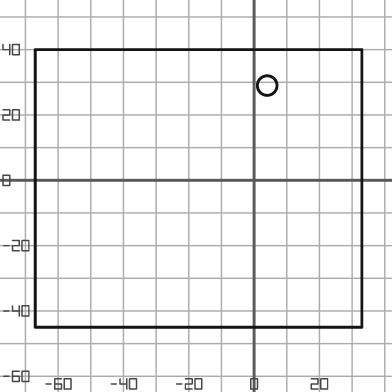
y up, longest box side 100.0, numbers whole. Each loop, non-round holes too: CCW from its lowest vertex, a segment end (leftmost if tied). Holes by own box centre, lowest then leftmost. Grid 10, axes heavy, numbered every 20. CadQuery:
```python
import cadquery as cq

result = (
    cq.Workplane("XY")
    .moveTo(-67.0, -45.0)
    .lineTo(33.0, -45.0)
    .lineTo(33.0, 40.0)
    .lineTo(-67.0, 40.0)
    .close()
    .moveTo(4.0, 29.0)
    .circle(3.0)
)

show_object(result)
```